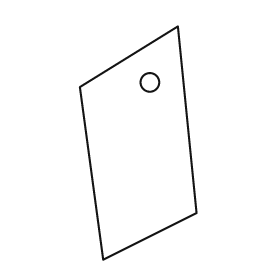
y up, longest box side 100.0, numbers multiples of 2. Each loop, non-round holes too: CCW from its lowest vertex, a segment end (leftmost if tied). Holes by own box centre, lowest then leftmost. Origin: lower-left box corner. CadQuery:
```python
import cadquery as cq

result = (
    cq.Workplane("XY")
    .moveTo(10.0, 0.0)
    .lineTo(50.0, 20.0)
    .lineTo(42.0, 100.0)
    .lineTo(0.0, 74.0)
    .close()
    .moveTo(30.0, 76.0)
    .circle(4.0)
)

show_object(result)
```